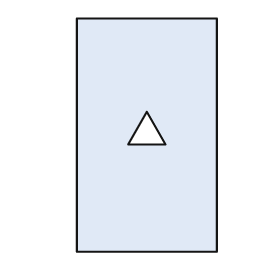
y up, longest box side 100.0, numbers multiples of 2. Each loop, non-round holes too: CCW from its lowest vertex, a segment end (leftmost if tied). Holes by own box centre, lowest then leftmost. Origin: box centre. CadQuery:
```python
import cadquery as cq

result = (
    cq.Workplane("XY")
    .moveTo(-30.0, -50.0)
    .lineTo(30.0, -50.0)
    .lineTo(30.0, 50.0)
    .lineTo(-30.0, 50.0)
    .close()
    .moveTo(-8.0, -4.0)
    .lineTo(8.0, -4.0)
    .lineTo(0.0, 10.0)
    .close()
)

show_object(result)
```